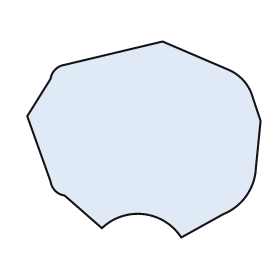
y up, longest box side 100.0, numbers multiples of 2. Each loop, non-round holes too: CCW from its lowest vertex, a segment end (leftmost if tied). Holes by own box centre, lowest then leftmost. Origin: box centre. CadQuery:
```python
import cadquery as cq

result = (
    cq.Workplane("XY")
    .moveTo(16.0, -42.0)
    .lineTo(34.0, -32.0)
    .threePointArc((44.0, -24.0), (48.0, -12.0))
    .lineTo(50.0, 8.0)
    .lineTo(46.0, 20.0)
    .threePointArc((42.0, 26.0), (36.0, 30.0))
    .lineTo(8.0, 42.0)
    .lineTo(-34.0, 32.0)
    .threePointArc((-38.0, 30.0), (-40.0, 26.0))
    .lineTo(-50.0, 10.0)
    .lineTo(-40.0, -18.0)
    .threePointArc((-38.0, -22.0), (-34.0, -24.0))
    .lineTo(-18.0, -38.0)
    .threePointArc((0.0, -32.0), (16.0, -42.0))
    .close()
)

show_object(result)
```